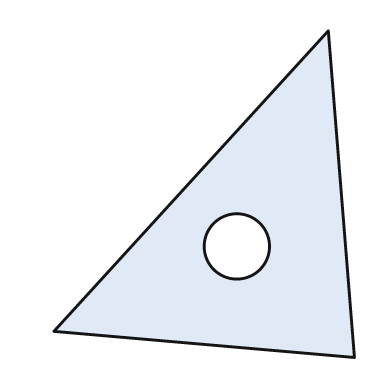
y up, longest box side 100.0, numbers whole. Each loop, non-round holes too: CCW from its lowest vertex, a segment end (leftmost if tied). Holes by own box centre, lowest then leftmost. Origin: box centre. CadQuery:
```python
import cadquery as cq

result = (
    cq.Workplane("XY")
    .moveTo(46.0, -50.0)
    .lineTo(38.0, 50.0)
    .lineTo(-46.0, -42.0)
    .close()
    .moveTo(10.0, -16.0)
    .circle(10.0)
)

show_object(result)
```